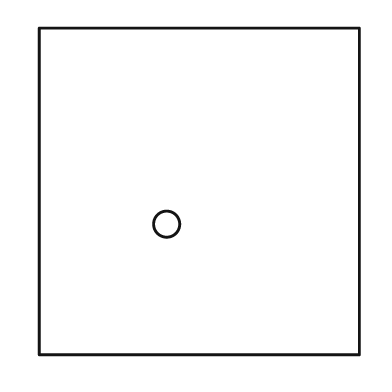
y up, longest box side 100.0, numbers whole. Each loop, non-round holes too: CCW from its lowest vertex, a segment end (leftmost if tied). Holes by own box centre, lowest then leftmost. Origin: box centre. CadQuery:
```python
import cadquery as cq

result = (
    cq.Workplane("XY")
    .moveTo(-49.0, -50.0)
    .lineTo(49.0, -50.0)
    .lineTo(49.0, 50.0)
    .lineTo(-49.0, 50.0)
    .close()
    .moveTo(-10.0, -10.0)
    .circle(4.0)
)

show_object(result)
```